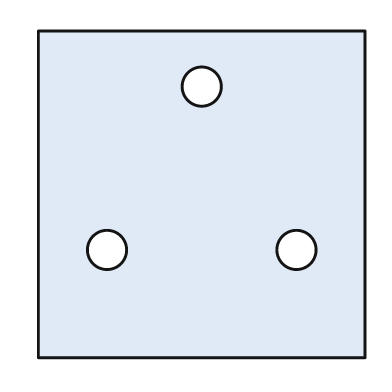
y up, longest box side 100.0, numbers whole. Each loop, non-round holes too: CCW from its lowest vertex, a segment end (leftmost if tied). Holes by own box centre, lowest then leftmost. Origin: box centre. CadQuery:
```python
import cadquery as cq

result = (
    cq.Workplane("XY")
    .moveTo(-50.0, -50.0)
    .lineTo(50.0, -50.0)
    .lineTo(50.0, 50.0)
    .lineTo(-50.0, 50.0)
    .close()
    .moveTo(-29.0, -17.0)
    .circle(6.0)
    .moveTo(29.0, -17.0)
    .circle(6.0)
    .moveTo(0.0, 33.0)
    .circle(6.0)
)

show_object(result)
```